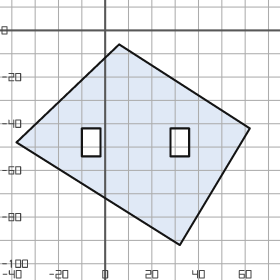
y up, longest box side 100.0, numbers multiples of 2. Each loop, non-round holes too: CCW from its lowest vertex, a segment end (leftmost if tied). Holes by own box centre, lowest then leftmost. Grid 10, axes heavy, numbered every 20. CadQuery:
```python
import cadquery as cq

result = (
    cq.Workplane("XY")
    .moveTo(32.0, -92.0)
    .lineTo(62.0, -42.0)
    .lineTo(6.0, -6.0)
    .lineTo(-38.0, -48.0)
    .close()
    .moveTo(-10.0, -54.0)
    .lineTo(-2.0, -54.0)
    .lineTo(-2.0, -42.0)
    .lineTo(-10.0, -42.0)
    .close()
    .moveTo(28.0, -54.0)
    .lineTo(36.0, -54.0)
    .lineTo(36.0, -42.0)
    .lineTo(28.0, -42.0)
    .close()
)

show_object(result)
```